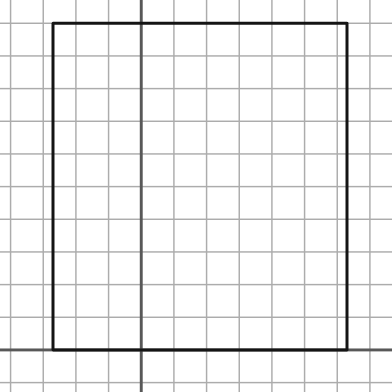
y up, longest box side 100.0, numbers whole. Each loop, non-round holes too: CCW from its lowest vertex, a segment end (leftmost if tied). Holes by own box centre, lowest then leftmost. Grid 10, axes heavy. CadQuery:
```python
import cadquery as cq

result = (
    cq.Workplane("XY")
    .moveTo(-27.0, 0.0)
    .lineTo(63.0, 0.0)
    .lineTo(63.0, 100.0)
    .lineTo(-27.0, 100.0)
    .close()
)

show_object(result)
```